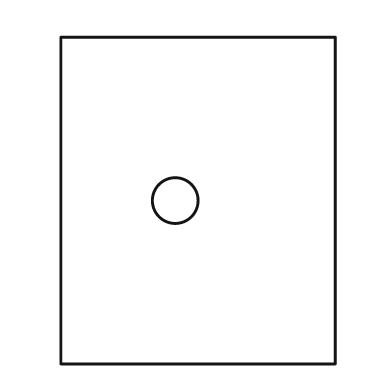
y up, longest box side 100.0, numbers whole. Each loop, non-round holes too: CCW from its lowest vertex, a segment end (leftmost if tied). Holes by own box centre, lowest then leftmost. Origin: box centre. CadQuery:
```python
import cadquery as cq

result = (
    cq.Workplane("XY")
    .moveTo(-42.0, -50.0)
    .lineTo(42.0, -50.0)
    .lineTo(42.0, 50.0)
    .lineTo(-42.0, 50.0)
    .close()
    .moveTo(-7.0, 0.0)
    .circle(7.0)
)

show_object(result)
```